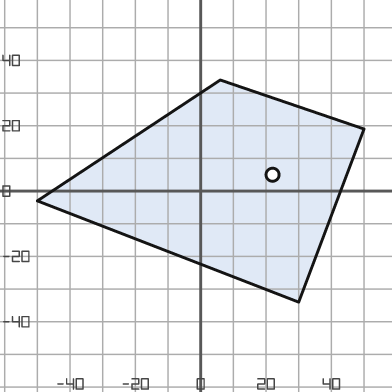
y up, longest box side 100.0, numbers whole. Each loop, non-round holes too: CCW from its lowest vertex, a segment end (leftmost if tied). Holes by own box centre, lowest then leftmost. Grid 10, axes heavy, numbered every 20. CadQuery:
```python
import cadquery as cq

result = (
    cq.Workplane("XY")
    .moveTo(30.0, -34.0)
    .lineTo(50.0, 19.0)
    .lineTo(6.0, 34.0)
    .lineTo(-50.0, -3.0)
    .close()
    .moveTo(22.0, 5.0)
    .circle(2.0)
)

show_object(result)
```